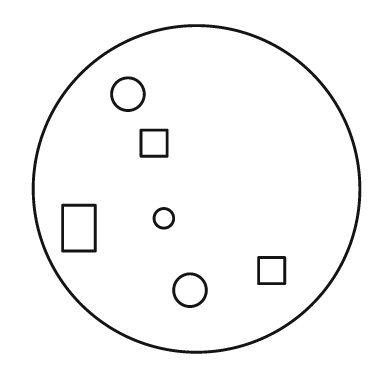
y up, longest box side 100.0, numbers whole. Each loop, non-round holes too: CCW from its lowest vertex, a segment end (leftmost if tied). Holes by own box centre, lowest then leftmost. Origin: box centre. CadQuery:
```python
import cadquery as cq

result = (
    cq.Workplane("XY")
    .moveTo(0.0, 0.0)
    .circle(50.0)
    .moveTo(-2.0, -31.0)
    .circle(5.0)
    .moveTo(19.0, -29.0)
    .lineTo(27.0, -29.0)
    .lineTo(27.0, -21.0)
    .lineTo(19.0, -21.0)
    .close()
    .moveTo(-41.0, -19.0)
    .lineTo(-31.0, -19.0)
    .lineTo(-31.0, -5.0)
    .lineTo(-41.0, -5.0)
    .close()
    .moveTo(-10.0, -9.0)
    .circle(3.0)
    .moveTo(-17.0, 10.0)
    .lineTo(-9.0, 10.0)
    .lineTo(-9.0, 18.0)
    .lineTo(-17.0, 18.0)
    .close()
    .moveTo(-21.0, 29.0)
    .circle(5.0)
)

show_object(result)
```